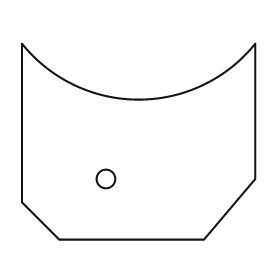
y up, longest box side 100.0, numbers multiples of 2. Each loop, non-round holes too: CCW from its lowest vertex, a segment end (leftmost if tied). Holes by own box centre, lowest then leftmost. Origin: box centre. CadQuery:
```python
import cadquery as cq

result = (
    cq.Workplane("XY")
    .moveTo(-34.0, -42.0)
    .lineTo(28.0, -42.0)
    .lineTo(50.0, -16.0)
    .lineTo(50.0, 42.0)
    .threePointArc((0.0, 18.0), (-50.0, 42.0))
    .lineTo(-50.0, -26.0)
    .close()
    .moveTo(-14.0, -16.0)
    .circle(4.0)
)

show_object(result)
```